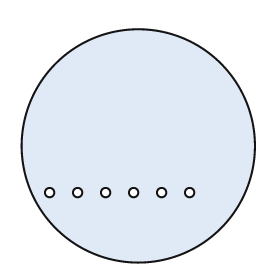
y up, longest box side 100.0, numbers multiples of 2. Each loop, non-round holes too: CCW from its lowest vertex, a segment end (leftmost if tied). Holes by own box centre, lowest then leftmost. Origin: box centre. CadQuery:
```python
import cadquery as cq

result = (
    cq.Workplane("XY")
    .moveTo(0.0, 0.0)
    .circle(50.0)
    .moveTo(-38.0, -20.0)
    .circle(2.0)
    .moveTo(-26.0, -20.0)
    .circle(2.0)
    .moveTo(-14.0, -20.0)
    .circle(2.0)
    .moveTo(-2.0, -20.0)
    .circle(2.0)
    .moveTo(10.0, -20.0)
    .circle(2.0)
    .moveTo(22.0, -20.0)
    .circle(2.0)
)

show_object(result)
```